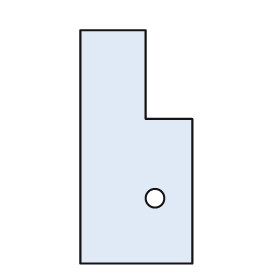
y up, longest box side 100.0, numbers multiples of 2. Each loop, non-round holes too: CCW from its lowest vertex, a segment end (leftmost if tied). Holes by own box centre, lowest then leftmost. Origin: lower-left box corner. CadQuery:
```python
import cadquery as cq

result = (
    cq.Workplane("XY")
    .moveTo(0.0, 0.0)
    .lineTo(48.0, 0.0)
    .lineTo(48.0, 62.0)
    .lineTo(28.0, 62.0)
    .lineTo(28.0, 100.0)
    .lineTo(0.0, 100.0)
    .close()
    .moveTo(32.0, 28.0)
    .circle(4.0)
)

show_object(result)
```